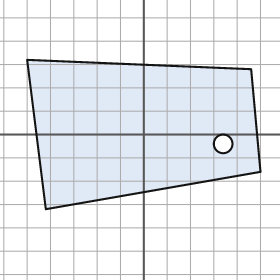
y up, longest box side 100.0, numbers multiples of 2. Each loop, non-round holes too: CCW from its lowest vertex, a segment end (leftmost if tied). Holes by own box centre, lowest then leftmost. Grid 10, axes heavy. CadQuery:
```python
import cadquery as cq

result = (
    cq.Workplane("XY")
    .moveTo(-42.0, -32.0)
    .lineTo(50.0, -16.0)
    .lineTo(46.0, 28.0)
    .lineTo(-50.0, 32.0)
    .close()
    .moveTo(34.0, -4.0)
    .circle(4.0)
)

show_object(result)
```